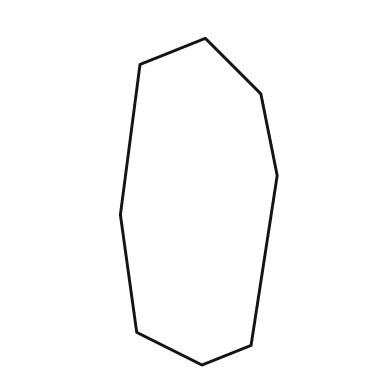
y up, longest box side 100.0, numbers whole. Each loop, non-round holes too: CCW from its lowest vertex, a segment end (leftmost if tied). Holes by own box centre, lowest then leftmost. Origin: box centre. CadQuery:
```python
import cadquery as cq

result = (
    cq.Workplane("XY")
    .moveTo(1.0, -50.0)
    .lineTo(16.0, -44.0)
    .lineTo(24.0, 8.0)
    .lineTo(19.0, 33.0)
    .lineTo(2.0, 50.0)
    .lineTo(-18.0, 42.0)
    .lineTo(-24.0, -4.0)
    .lineTo(-19.0, -40.0)
    .close()
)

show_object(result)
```